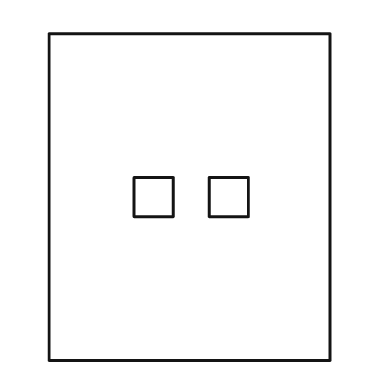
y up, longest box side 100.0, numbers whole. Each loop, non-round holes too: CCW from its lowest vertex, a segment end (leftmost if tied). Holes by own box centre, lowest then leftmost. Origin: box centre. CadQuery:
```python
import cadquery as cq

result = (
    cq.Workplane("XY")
    .moveTo(-43.0, -50.0)
    .lineTo(43.0, -50.0)
    .lineTo(43.0, 50.0)
    .lineTo(-43.0, 50.0)
    .close()
    .moveTo(-17.0, -6.0)
    .lineTo(-5.0, -6.0)
    .lineTo(-5.0, 6.0)
    .lineTo(-17.0, 6.0)
    .close()
    .moveTo(6.0, -6.0)
    .lineTo(18.0, -6.0)
    .lineTo(18.0, 6.0)
    .lineTo(6.0, 6.0)
    .close()
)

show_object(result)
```